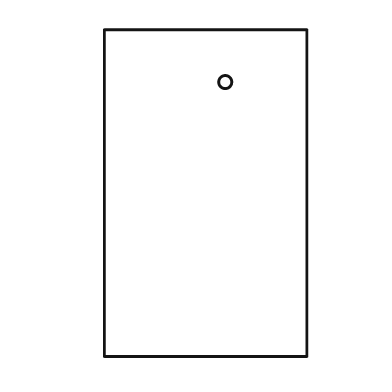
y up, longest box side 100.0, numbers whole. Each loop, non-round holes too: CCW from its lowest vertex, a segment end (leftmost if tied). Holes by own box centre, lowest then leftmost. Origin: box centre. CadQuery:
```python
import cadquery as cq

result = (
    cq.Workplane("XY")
    .moveTo(-31.0, -50.0)
    .lineTo(31.0, -50.0)
    .lineTo(31.0, 50.0)
    .lineTo(-31.0, 50.0)
    .close()
    .moveTo(6.0, 34.0)
    .circle(2.0)
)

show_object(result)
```